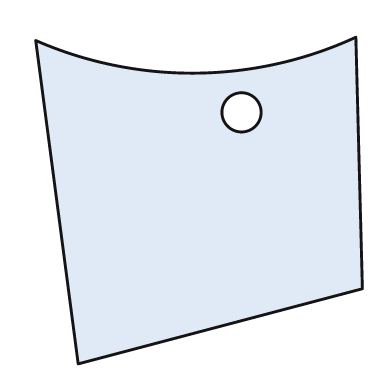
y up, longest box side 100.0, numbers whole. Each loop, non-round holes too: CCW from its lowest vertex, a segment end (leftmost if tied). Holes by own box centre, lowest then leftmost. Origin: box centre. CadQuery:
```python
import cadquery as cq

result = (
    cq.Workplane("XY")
    .moveTo(-37.0, -50.0)
    .lineTo(50.0, -27.0)
    .lineTo(48.0, 50.0)
    .threePointArc((-1.0, 39.0), (-50.0, 49.0))
    .close()
    .moveTo(13.0, 27.0)
    .circle(6.0)
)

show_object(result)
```